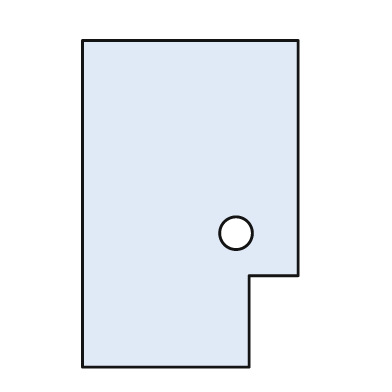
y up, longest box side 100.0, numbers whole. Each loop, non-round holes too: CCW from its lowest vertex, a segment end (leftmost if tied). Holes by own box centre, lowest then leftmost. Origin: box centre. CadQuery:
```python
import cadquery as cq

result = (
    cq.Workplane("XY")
    .moveTo(-33.0, -50.0)
    .lineTo(18.0, -50.0)
    .lineTo(18.0, -22.0)
    .lineTo(33.0, -22.0)
    .lineTo(33.0, 50.0)
    .lineTo(-33.0, 50.0)
    .close()
    .moveTo(14.0, -9.0)
    .circle(5.0)
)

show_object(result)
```